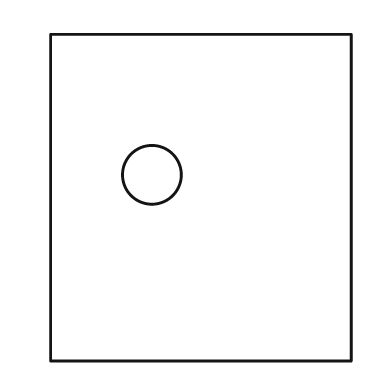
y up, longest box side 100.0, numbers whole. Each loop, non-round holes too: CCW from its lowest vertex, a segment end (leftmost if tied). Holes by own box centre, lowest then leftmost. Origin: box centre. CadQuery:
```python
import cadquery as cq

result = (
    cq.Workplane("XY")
    .moveTo(-46.0, -50.0)
    .lineTo(46.0, -50.0)
    .lineTo(46.0, 50.0)
    .lineTo(-46.0, 50.0)
    .close()
    .moveTo(-15.0, 7.0)
    .circle(9.0)
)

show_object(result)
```